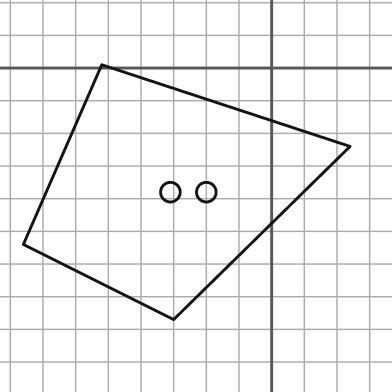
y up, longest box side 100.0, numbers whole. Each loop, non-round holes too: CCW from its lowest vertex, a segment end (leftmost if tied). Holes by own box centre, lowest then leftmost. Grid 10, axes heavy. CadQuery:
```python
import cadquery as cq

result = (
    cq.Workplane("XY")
    .moveTo(-30.0, -77.0)
    .lineTo(24.0, -24.0)
    .lineTo(-52.0, 1.0)
    .lineTo(-76.0, -54.0)
    .close()
    .moveTo(-31.0, -38.0)
    .circle(3.0)
    .moveTo(-20.0, -38.0)
    .circle(3.0)
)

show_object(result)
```